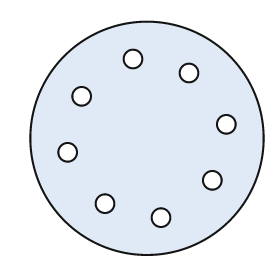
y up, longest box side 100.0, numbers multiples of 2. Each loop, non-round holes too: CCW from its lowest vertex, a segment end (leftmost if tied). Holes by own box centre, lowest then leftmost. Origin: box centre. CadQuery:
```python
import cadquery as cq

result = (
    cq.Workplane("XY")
    .moveTo(0.0, 0.0)
    .circle(50.0)
    .moveTo(6.0, -34.0)
    .circle(4.0)
    .moveTo(-18.0, -28.0)
    .circle(4.0)
    .moveTo(28.0, -18.0)
    .circle(4.0)
    .moveTo(-34.0, -6.0)
    .circle(4.0)
    .moveTo(34.0, 6.0)
    .circle(4.0)
    .moveTo(-28.0, 18.0)
    .circle(4.0)
    .moveTo(18.0, 28.0)
    .circle(4.0)
    .moveTo(-6.0, 34.0)
    .circle(4.0)
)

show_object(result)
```